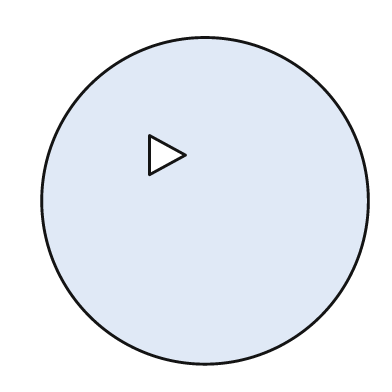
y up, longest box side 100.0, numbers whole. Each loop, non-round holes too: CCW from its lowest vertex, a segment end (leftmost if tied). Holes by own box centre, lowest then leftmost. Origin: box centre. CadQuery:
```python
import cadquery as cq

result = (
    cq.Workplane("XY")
    .moveTo(0.0, 0.0)
    .circle(50.0)
    .moveTo(-17.0, 8.0)
    .lineTo(-6.0, 14.0)
    .lineTo(-17.0, 20.0)
    .close()
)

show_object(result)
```